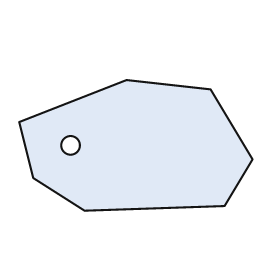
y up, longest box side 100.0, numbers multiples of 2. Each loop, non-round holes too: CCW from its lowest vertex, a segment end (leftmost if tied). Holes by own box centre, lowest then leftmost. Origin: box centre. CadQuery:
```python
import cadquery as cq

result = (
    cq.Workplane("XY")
    .moveTo(-22.0, -28.0)
    .lineTo(38.0, -26.0)
    .lineTo(50.0, -6.0)
    .lineTo(32.0, 24.0)
    .lineTo(-4.0, 28.0)
    .lineTo(-50.0, 10.0)
    .lineTo(-44.0, -14.0)
    .close()
    .moveTo(-28.0, 0.0)
    .circle(4.0)
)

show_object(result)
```